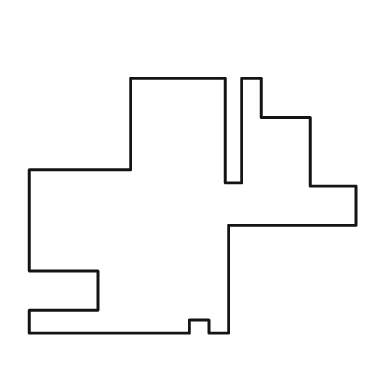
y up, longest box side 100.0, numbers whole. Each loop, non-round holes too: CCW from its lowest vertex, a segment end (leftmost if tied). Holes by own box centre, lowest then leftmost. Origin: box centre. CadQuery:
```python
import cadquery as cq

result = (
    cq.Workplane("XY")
    .moveTo(-50.0, -39.0)
    .lineTo(-1.0, -39.0)
    .lineTo(-1.0, -35.0)
    .lineTo(5.0, -35.0)
    .lineTo(5.0, -39.0)
    .lineTo(11.0, -39.0)
    .lineTo(11.0, -6.0)
    .lineTo(50.0, -6.0)
    .lineTo(50.0, 6.0)
    .lineTo(36.0, 6.0)
    .lineTo(36.0, 27.0)
    .lineTo(21.0, 27.0)
    .lineTo(21.0, 39.0)
    .lineTo(15.0, 39.0)
    .lineTo(15.0, 7.0)
    .lineTo(10.0, 7.0)
    .lineTo(10.0, 39.0)
    .lineTo(-19.0, 39.0)
    .lineTo(-19.0, 11.0)
    .lineTo(-50.0, 11.0)
    .lineTo(-50.0, -20.0)
    .lineTo(-29.0, -20.0)
    .lineTo(-29.0, -32.0)
    .lineTo(-50.0, -32.0)
    .close()
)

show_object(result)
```